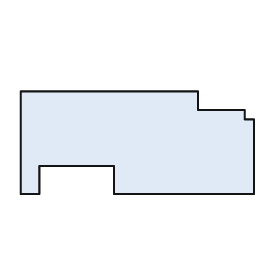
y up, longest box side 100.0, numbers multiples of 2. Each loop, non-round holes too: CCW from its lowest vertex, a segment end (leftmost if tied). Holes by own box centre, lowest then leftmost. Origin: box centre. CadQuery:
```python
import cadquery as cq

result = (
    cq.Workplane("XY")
    .moveTo(-50.0, -22.0)
    .lineTo(-42.0, -22.0)
    .lineTo(-42.0, -10.0)
    .lineTo(-10.0, -10.0)
    .lineTo(-10.0, -22.0)
    .lineTo(50.0, -22.0)
    .lineTo(50.0, 10.0)
    .lineTo(46.0, 10.0)
    .lineTo(46.0, 14.0)
    .lineTo(26.0, 14.0)
    .lineTo(26.0, 22.0)
    .lineTo(-50.0, 22.0)
    .close()
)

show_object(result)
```